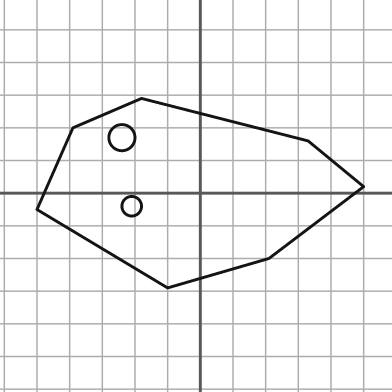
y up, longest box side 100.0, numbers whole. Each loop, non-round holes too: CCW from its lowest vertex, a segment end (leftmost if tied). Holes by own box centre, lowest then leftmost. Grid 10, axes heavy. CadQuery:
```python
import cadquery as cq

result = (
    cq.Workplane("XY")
    .moveTo(-10.0, -29.0)
    .lineTo(21.0, -20.0)
    .lineTo(50.0, 2.0)
    .lineTo(33.0, 16.0)
    .lineTo(-18.0, 29.0)
    .lineTo(-39.0, 20.0)
    .lineTo(-50.0, -5.0)
    .close()
    .moveTo(-21.0, -4.0)
    .circle(3.0)
    .moveTo(-24.0, 17.0)
    .circle(4.0)
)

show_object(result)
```